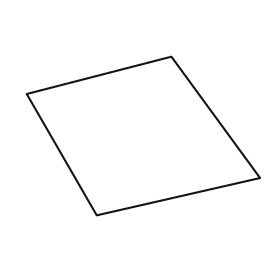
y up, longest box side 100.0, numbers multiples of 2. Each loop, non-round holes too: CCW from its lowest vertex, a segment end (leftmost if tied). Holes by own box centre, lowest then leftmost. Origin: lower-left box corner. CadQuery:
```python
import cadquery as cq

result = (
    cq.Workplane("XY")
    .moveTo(30.0, 0.0)
    .lineTo(100.0, 16.0)
    .lineTo(62.0, 68.0)
    .lineTo(0.0, 52.0)
    .close()
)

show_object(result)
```